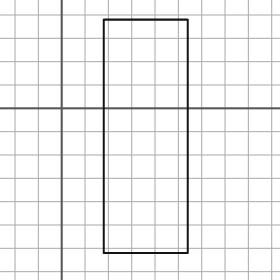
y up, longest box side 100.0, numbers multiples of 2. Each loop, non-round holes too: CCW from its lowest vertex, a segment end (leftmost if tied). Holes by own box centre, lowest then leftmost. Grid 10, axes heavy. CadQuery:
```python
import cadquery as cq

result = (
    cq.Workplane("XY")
    .moveTo(18.0, -62.0)
    .lineTo(54.0, -62.0)
    .lineTo(54.0, 38.0)
    .lineTo(18.0, 38.0)
    .close()
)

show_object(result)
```